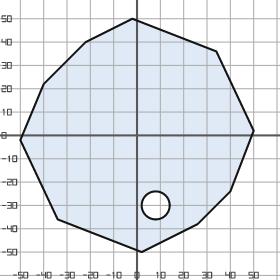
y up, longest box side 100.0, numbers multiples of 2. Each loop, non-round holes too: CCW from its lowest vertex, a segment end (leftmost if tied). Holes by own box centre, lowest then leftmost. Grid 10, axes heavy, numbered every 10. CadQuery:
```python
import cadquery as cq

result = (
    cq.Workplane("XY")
    .moveTo(2.0, -50.0)
    .lineTo(26.0, -38.0)
    .lineTo(40.0, -24.0)
    .lineTo(50.0, 2.0)
    .lineTo(34.0, 36.0)
    .lineTo(-2.0, 50.0)
    .lineTo(-22.0, 40.0)
    .lineTo(-40.0, 22.0)
    .lineTo(-50.0, -2.0)
    .lineTo(-34.0, -36.0)
    .close()
    .moveTo(8.0, -30.0)
    .circle(6.0)
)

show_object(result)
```